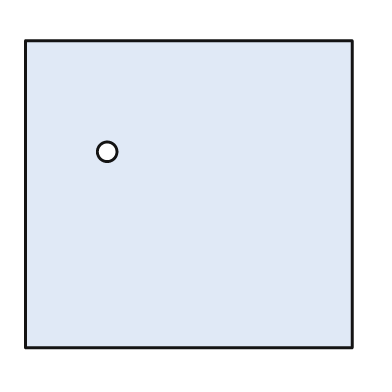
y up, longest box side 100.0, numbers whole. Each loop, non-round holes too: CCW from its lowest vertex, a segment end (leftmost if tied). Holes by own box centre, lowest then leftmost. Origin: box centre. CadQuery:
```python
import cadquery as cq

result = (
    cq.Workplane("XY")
    .moveTo(-50.0, -47.0)
    .lineTo(50.0, -47.0)
    .lineTo(50.0, 47.0)
    .lineTo(-50.0, 47.0)
    .close()
    .moveTo(-25.0, 13.0)
    .circle(3.0)
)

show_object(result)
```